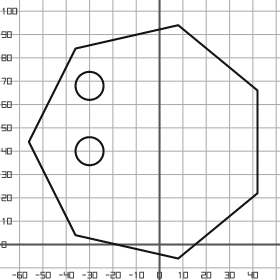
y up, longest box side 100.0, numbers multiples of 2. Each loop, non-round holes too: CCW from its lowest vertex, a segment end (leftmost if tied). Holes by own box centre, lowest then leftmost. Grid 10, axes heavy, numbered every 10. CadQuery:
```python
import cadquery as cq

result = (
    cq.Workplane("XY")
    .moveTo(8.0, -6.0)
    .lineTo(42.0, 22.0)
    .lineTo(42.0, 66.0)
    .lineTo(8.0, 94.0)
    .lineTo(-36.0, 84.0)
    .lineTo(-56.0, 44.0)
    .lineTo(-36.0, 4.0)
    .close()
    .moveTo(-30.0, 40.0)
    .circle(6.0)
    .moveTo(-30.0, 68.0)
    .circle(6.0)
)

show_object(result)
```